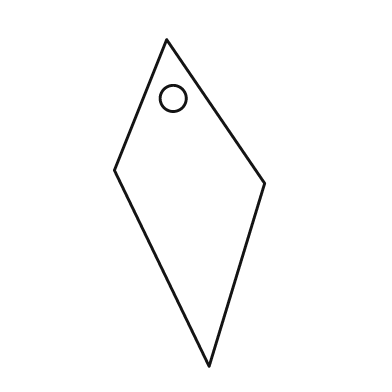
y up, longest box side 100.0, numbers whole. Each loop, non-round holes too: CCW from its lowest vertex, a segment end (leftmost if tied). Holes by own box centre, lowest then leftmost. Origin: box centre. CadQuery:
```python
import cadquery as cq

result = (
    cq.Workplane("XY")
    .moveTo(6.0, -50.0)
    .lineTo(23.0, 6.0)
    .lineTo(-7.0, 50.0)
    .lineTo(-23.0, 10.0)
    .close()
    .moveTo(-5.0, 32.0)
    .circle(4.0)
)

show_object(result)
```